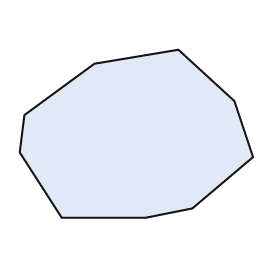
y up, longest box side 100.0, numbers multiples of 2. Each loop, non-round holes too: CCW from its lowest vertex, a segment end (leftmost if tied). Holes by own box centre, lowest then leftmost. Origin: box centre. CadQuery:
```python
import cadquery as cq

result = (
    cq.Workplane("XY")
    .moveTo(-32.0, -36.0)
    .lineTo(4.0, -36.0)
    .lineTo(24.0, -32.0)
    .lineTo(50.0, -10.0)
    .lineTo(42.0, 14.0)
    .lineTo(18.0, 36.0)
    .lineTo(-18.0, 30.0)
    .lineTo(-48.0, 8.0)
    .lineTo(-50.0, -8.0)
    .close()
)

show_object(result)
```